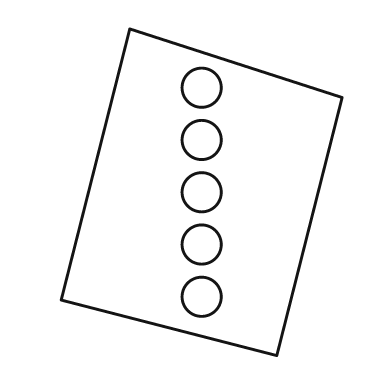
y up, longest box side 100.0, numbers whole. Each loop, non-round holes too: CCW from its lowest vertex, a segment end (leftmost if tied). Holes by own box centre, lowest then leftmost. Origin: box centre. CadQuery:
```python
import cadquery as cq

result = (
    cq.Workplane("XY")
    .moveTo(23.0, -50.0)
    .lineTo(43.0, 29.0)
    .lineTo(-22.0, 50.0)
    .lineTo(-43.0, -33.0)
    .close()
    .moveTo(0.0, -32.0)
    .circle(6.0)
    .moveTo(0.0, -16.0)
    .circle(6.0)
    .moveTo(0.0, 0.0)
    .circle(6.0)
    .moveTo(0.0, 16.0)
    .circle(6.0)
    .moveTo(0.0, 32.0)
    .circle(6.0)
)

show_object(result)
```